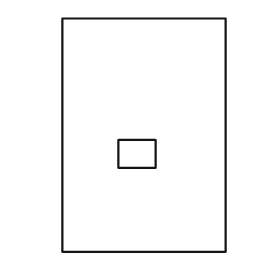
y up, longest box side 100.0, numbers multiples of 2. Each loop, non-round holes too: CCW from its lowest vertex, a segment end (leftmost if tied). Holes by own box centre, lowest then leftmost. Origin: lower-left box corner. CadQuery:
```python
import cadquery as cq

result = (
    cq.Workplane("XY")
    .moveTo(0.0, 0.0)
    .lineTo(70.0, 0.0)
    .lineTo(70.0, 100.0)
    .lineTo(0.0, 100.0)
    .close()
    .moveTo(24.0, 36.0)
    .lineTo(40.0, 36.0)
    .lineTo(40.0, 48.0)
    .lineTo(24.0, 48.0)
    .close()
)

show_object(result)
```